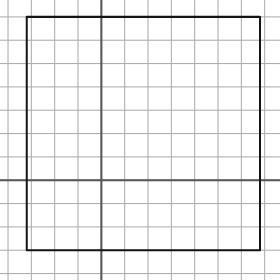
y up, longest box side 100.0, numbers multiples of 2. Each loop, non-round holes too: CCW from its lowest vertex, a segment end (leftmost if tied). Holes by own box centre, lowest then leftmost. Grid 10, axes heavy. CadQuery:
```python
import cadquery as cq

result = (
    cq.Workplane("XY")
    .moveTo(-32.0, -30.0)
    .lineTo(68.0, -30.0)
    .lineTo(68.0, 70.0)
    .lineTo(-32.0, 70.0)
    .close()
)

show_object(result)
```